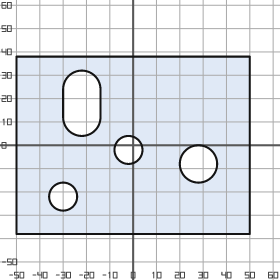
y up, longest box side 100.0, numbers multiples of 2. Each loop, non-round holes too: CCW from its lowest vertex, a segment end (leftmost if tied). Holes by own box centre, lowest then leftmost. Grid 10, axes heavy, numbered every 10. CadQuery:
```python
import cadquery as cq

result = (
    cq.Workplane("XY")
    .moveTo(-50.0, -38.0)
    .lineTo(50.0, -38.0)
    .lineTo(50.0, 38.0)
    .lineTo(-50.0, 38.0)
    .close()
    .moveTo(-30.0, -22.0)
    .circle(6.0)
    .moveTo(28.0, -8.0)
    .circle(8.0)
    .moveTo(-2.0, -2.0)
    .circle(6.0)
    .moveTo(-30.0, 12.0)
    .threePointArc((-22.0, 4.0), (-14.0, 12.0))
    .lineTo(-14.0, 24.0)
    .threePointArc((-22.0, 32.0), (-30.0, 24.0))
    .close()
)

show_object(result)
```